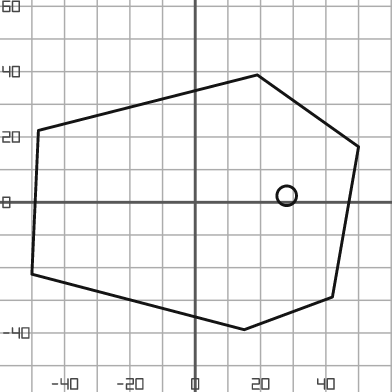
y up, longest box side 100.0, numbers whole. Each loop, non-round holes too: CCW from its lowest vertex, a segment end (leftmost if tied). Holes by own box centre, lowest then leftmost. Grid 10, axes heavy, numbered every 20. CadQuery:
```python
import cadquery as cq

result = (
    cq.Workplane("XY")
    .moveTo(15.0, -39.0)
    .lineTo(42.0, -29.0)
    .lineTo(50.0, 17.0)
    .lineTo(19.0, 39.0)
    .lineTo(-48.0, 22.0)
    .lineTo(-50.0, -22.0)
    .close()
    .moveTo(28.0, 2.0)
    .circle(3.0)
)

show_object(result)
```